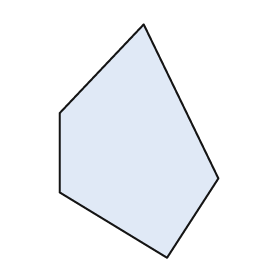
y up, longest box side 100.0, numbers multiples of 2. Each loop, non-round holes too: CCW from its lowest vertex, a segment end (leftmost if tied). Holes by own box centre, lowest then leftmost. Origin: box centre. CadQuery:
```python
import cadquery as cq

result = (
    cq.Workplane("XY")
    .moveTo(12.0, -50.0)
    .lineTo(34.0, -16.0)
    .lineTo(2.0, 50.0)
    .lineTo(-34.0, 12.0)
    .lineTo(-34.0, -22.0)
    .close()
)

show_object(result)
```